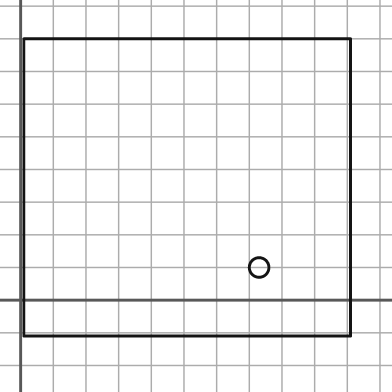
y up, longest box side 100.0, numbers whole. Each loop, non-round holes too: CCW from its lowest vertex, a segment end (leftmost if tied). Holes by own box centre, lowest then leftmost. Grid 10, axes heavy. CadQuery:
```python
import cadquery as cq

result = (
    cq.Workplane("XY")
    .moveTo(1.0, -11.0)
    .lineTo(101.0, -11.0)
    .lineTo(101.0, 80.0)
    .lineTo(1.0, 80.0)
    .close()
    .moveTo(73.0, 10.0)
    .circle(3.0)
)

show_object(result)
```